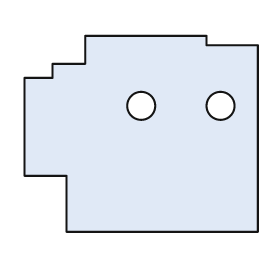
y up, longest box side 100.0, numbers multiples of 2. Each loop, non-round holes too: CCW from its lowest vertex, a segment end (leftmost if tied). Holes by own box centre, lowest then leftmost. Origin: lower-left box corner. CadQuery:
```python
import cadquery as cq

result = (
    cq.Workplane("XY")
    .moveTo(18.0, 0.0)
    .lineTo(100.0, 0.0)
    .lineTo(100.0, 80.0)
    .lineTo(78.0, 80.0)
    .lineTo(78.0, 84.0)
    .lineTo(26.0, 84.0)
    .lineTo(26.0, 72.0)
    .lineTo(12.0, 72.0)
    .lineTo(12.0, 66.0)
    .lineTo(0.0, 66.0)
    .lineTo(0.0, 24.0)
    .lineTo(18.0, 24.0)
    .close()
    .moveTo(50.0, 54.0)
    .circle(6.0)
    .moveTo(84.0, 54.0)
    .circle(6.0)
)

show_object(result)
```